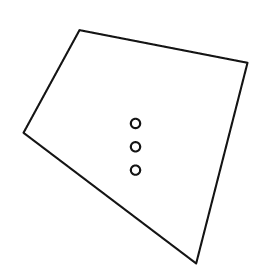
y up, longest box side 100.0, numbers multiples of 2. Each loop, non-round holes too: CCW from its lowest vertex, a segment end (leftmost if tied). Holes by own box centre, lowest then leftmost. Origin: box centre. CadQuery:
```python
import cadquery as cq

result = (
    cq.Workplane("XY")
    .moveTo(26.0, -50.0)
    .lineTo(48.0, 36.0)
    .lineTo(-24.0, 50.0)
    .lineTo(-48.0, 6.0)
    .close()
    .moveTo(0.0, -10.0)
    .circle(2.0)
    .moveTo(0.0, 0.0)
    .circle(2.0)
    .moveTo(0.0, 10.0)
    .circle(2.0)
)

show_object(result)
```